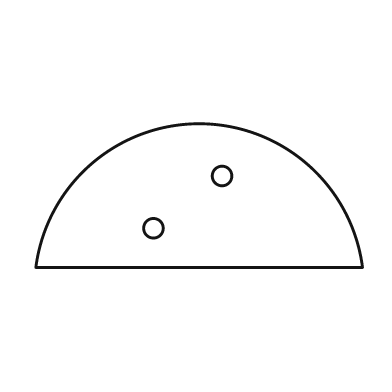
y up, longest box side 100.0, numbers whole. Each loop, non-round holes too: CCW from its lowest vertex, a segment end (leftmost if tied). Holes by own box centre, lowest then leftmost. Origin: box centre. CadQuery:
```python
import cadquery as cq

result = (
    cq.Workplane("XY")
    .moveTo(-50.0, -22.0)
    .lineTo(50.0, -22.0)
    .threePointArc((0.0, 22.0), (-50.0, -22.0))
    .close()
    .moveTo(-14.0, -10.0)
    .circle(3.0)
    .moveTo(7.0, 6.0)
    .circle(3.0)
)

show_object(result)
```